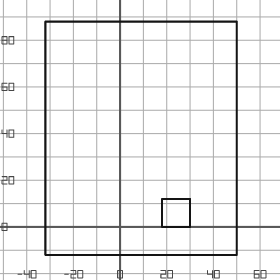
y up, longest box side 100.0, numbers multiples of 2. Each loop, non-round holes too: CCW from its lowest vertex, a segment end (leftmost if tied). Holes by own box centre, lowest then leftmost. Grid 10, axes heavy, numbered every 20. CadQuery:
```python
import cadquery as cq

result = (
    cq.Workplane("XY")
    .moveTo(-32.0, -12.0)
    .lineTo(50.0, -12.0)
    .lineTo(50.0, 88.0)
    .lineTo(-32.0, 88.0)
    .close()
    .moveTo(18.0, 0.0)
    .lineTo(30.0, 0.0)
    .lineTo(30.0, 12.0)
    .lineTo(18.0, 12.0)
    .close()
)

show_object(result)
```